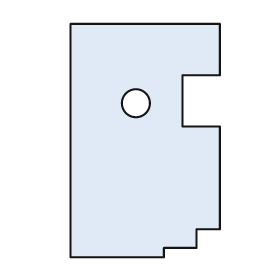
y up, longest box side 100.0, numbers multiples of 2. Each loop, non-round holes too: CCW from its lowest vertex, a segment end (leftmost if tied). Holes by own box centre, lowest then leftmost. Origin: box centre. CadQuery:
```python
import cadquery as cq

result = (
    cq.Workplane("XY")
    .moveTo(-32.0, -50.0)
    .lineTo(8.0, -50.0)
    .lineTo(8.0, -46.0)
    .lineTo(22.0, -46.0)
    .lineTo(22.0, -38.0)
    .lineTo(32.0, -38.0)
    .lineTo(32.0, 6.0)
    .lineTo(16.0, 6.0)
    .lineTo(16.0, 28.0)
    .lineTo(32.0, 28.0)
    .lineTo(32.0, 50.0)
    .lineTo(-32.0, 50.0)
    .close()
    .moveTo(-4.0, 16.0)
    .circle(6.0)
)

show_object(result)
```